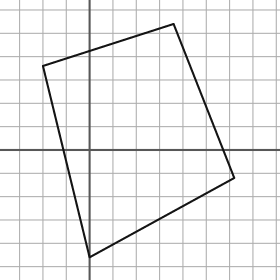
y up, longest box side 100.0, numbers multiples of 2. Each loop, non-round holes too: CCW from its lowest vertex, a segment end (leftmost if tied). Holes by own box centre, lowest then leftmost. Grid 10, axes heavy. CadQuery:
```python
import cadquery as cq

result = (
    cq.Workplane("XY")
    .moveTo(0.0, -46.0)
    .lineTo(62.0, -12.0)
    .lineTo(36.0, 54.0)
    .lineTo(-20.0, 36.0)
    .close()
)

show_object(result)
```